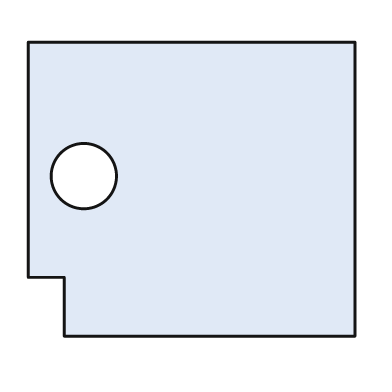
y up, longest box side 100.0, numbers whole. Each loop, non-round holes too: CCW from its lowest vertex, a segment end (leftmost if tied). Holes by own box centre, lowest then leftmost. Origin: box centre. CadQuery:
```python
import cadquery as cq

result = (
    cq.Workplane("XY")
    .moveTo(-39.0, -45.0)
    .lineTo(50.0, -45.0)
    .lineTo(50.0, 45.0)
    .lineTo(-50.0, 45.0)
    .lineTo(-50.0, -27.0)
    .lineTo(-39.0, -27.0)
    .close()
    .moveTo(-33.0, 4.0)
    .circle(10.0)
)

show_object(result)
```